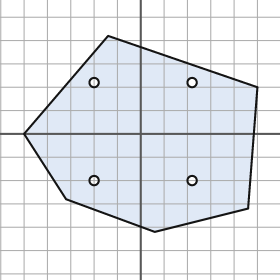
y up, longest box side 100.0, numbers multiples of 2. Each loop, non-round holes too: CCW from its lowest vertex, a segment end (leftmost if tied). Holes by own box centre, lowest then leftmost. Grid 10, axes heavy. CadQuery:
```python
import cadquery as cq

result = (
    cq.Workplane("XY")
    .moveTo(6.0, -42.0)
    .lineTo(46.0, -32.0)
    .lineTo(50.0, 20.0)
    .lineTo(-14.0, 42.0)
    .lineTo(-50.0, 0.0)
    .lineTo(-32.0, -28.0)
    .close()
    .moveTo(-20.0, -20.0)
    .circle(2.0)
    .moveTo(22.0, -20.0)
    .circle(2.0)
    .moveTo(-20.0, 22.0)
    .circle(2.0)
    .moveTo(22.0, 22.0)
    .circle(2.0)
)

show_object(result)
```